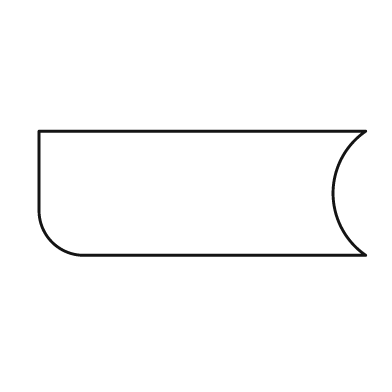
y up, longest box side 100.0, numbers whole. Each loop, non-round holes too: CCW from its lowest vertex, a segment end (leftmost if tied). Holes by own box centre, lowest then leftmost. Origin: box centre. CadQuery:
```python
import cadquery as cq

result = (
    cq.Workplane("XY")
    .moveTo(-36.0, -19.0)
    .lineTo(50.0, -19.0)
    .threePointArc((40.0, 0.0), (50.0, 19.0))
    .lineTo(-50.0, 19.0)
    .lineTo(-50.0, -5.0)
    .threePointArc((-46.0, -15.0), (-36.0, -19.0))
    .close()
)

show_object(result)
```